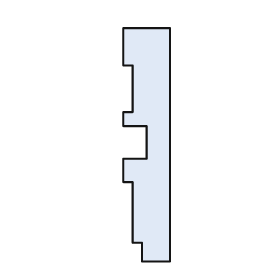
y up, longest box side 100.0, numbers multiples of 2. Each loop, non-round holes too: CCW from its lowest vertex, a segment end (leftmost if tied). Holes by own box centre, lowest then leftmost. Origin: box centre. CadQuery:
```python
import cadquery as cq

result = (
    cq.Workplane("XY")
    .moveTo(-2.0, -50.0)
    .lineTo(10.0, -50.0)
    .lineTo(10.0, 50.0)
    .lineTo(-10.0, 50.0)
    .lineTo(-10.0, 34.0)
    .lineTo(-6.0, 34.0)
    .lineTo(-6.0, 14.0)
    .lineTo(-10.0, 14.0)
    .lineTo(-10.0, 8.0)
    .lineTo(0.0, 8.0)
    .lineTo(0.0, -6.0)
    .lineTo(-10.0, -6.0)
    .lineTo(-10.0, -16.0)
    .lineTo(-6.0, -16.0)
    .lineTo(-6.0, -42.0)
    .lineTo(-2.0, -42.0)
    .close()
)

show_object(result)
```